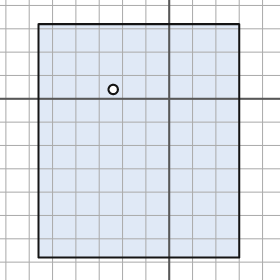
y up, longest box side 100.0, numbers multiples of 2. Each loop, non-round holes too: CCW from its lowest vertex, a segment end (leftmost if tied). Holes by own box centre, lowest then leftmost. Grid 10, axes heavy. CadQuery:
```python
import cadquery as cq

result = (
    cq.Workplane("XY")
    .moveTo(-56.0, -68.0)
    .lineTo(30.0, -68.0)
    .lineTo(30.0, 32.0)
    .lineTo(-56.0, 32.0)
    .close()
    .moveTo(-24.0, 4.0)
    .circle(2.0)
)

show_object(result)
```